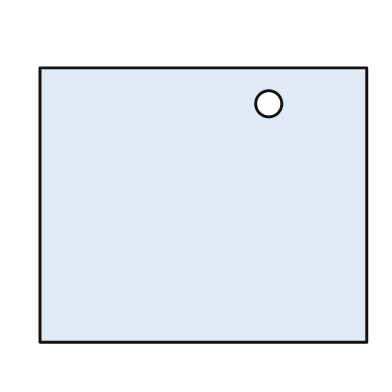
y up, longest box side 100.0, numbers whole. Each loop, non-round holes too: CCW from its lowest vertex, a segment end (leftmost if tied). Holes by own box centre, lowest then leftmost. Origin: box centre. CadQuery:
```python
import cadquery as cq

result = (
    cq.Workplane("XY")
    .moveTo(-50.0, -42.0)
    .lineTo(50.0, -42.0)
    .lineTo(50.0, 42.0)
    .lineTo(-50.0, 42.0)
    .close()
    .moveTo(20.0, 31.0)
    .circle(4.0)
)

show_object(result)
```